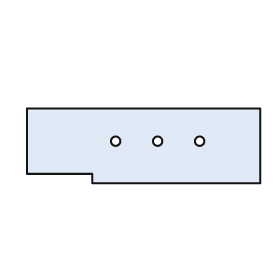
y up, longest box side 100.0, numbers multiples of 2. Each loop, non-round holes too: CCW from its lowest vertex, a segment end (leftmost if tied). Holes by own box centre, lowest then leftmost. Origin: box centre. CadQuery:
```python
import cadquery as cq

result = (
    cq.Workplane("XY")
    .moveTo(-22.0, -16.0)
    .lineTo(50.0, -16.0)
    .lineTo(50.0, 16.0)
    .lineTo(-50.0, 16.0)
    .lineTo(-50.0, -12.0)
    .lineTo(-22.0, -12.0)
    .close()
    .moveTo(-12.0, 2.0)
    .circle(2.0)
    .moveTo(6.0, 2.0)
    .circle(2.0)
    .moveTo(24.0, 2.0)
    .circle(2.0)
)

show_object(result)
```